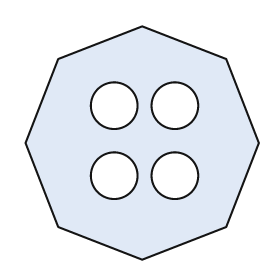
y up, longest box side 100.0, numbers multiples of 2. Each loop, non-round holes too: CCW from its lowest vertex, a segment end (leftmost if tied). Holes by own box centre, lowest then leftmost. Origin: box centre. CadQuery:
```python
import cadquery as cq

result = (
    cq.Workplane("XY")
    .moveTo(0.0, -50.0)
    .lineTo(36.0, -36.0)
    .lineTo(50.0, 0.0)
    .lineTo(36.0, 36.0)
    .lineTo(0.0, 50.0)
    .lineTo(-36.0, 36.0)
    .lineTo(-50.0, 0.0)
    .lineTo(-36.0, -36.0)
    .close()
    .moveTo(-12.0, -14.0)
    .circle(10.0)
    .moveTo(14.0, -14.0)
    .circle(10.0)
    .moveTo(-12.0, 16.0)
    .circle(10.0)
    .moveTo(14.0, 16.0)
    .circle(10.0)
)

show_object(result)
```